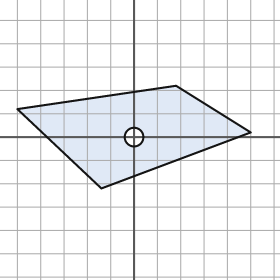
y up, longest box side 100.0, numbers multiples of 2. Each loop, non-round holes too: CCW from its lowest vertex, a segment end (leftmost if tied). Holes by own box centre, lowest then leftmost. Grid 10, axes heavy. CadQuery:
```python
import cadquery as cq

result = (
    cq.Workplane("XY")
    .moveTo(-14.0, -22.0)
    .lineTo(50.0, 2.0)
    .lineTo(18.0, 22.0)
    .lineTo(-50.0, 12.0)
    .close()
    .moveTo(0.0, 0.0)
    .circle(4.0)
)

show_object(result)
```